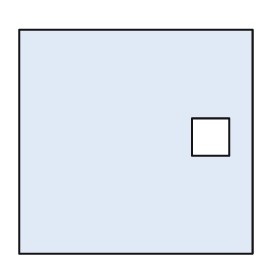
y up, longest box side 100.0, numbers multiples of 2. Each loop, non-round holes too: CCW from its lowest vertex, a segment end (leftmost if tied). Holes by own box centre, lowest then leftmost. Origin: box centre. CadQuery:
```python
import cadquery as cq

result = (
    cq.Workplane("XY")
    .moveTo(-50.0, -48.0)
    .lineTo(50.0, -48.0)
    .lineTo(50.0, 48.0)
    .lineTo(-50.0, 48.0)
    .close()
    .moveTo(24.0, -6.0)
    .lineTo(40.0, -6.0)
    .lineTo(40.0, 10.0)
    .lineTo(24.0, 10.0)
    .close()
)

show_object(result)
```